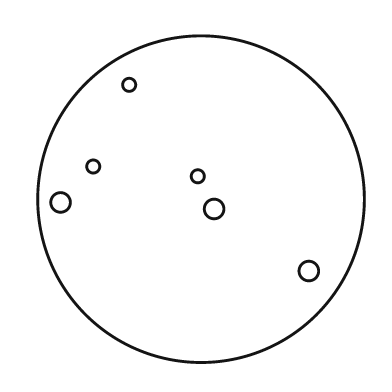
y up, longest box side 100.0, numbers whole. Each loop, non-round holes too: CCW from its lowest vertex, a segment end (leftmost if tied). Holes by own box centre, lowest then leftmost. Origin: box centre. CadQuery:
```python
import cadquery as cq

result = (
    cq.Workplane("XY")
    .moveTo(0.0, 0.0)
    .circle(50.0)
    .moveTo(33.0, -22.0)
    .circle(3.0)
    .moveTo(4.0, -3.0)
    .circle(3.0)
    .moveTo(-43.0, -1.0)
    .circle(3.0)
    .moveTo(-1.0, 7.0)
    .circle(2.0)
    .moveTo(-33.0, 10.0)
    .circle(2.0)
    .moveTo(-22.0, 35.0)
    .circle(2.0)
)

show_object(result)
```